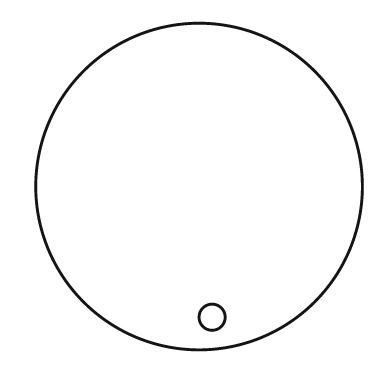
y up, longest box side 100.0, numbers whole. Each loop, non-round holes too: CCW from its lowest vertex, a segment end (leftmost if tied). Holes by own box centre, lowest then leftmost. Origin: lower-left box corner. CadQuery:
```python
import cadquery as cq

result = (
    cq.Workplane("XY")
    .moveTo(50.0, 50.0)
    .circle(50.0)
    .moveTo(54.0, 10.0)
    .circle(4.0)
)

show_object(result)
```